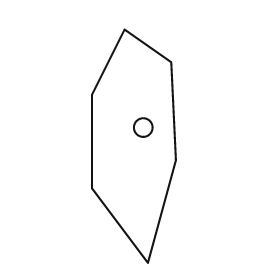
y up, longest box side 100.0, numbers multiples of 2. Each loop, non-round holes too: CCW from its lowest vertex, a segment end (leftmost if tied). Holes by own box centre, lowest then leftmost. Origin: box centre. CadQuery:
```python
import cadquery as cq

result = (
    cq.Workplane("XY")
    .moveTo(6.0, -50.0)
    .lineTo(18.0, -6.0)
    .lineTo(16.0, 36.0)
    .lineTo(-4.0, 50.0)
    .lineTo(-18.0, 22.0)
    .lineTo(-18.0, -18.0)
    .close()
    .moveTo(4.0, 8.0)
    .circle(4.0)
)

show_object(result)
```